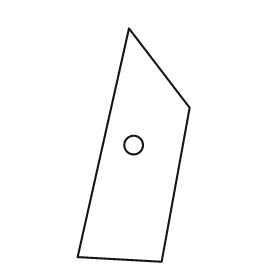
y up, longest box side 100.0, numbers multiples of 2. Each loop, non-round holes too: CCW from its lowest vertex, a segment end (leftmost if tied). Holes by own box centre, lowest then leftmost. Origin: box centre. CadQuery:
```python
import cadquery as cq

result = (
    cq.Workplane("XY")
    .moveTo(12.0, -50.0)
    .lineTo(24.0, 16.0)
    .lineTo(-2.0, 50.0)
    .lineTo(-24.0, -48.0)
    .close()
    .moveTo(0.0, 0.0)
    .circle(4.0)
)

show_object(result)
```